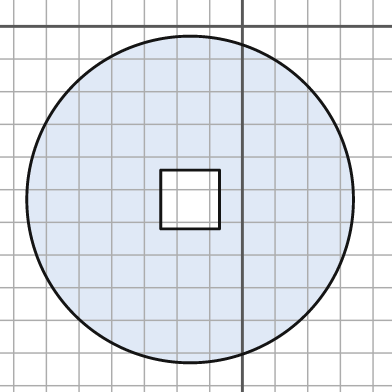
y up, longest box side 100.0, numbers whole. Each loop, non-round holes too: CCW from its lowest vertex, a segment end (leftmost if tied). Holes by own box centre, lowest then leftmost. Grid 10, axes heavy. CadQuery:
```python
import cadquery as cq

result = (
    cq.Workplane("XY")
    .moveTo(-16.0, -53.0)
    .circle(50.0)
    .moveTo(-25.0, -62.0)
    .lineTo(-7.0, -62.0)
    .lineTo(-7.0, -44.0)
    .lineTo(-25.0, -44.0)
    .close()
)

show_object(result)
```